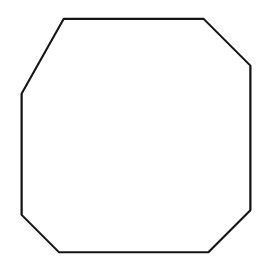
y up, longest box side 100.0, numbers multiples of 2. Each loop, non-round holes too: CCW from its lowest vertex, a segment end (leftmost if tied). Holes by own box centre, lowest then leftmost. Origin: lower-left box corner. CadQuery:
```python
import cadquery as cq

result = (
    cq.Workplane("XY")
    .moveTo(16.0, 0.0)
    .lineTo(80.0, 0.0)
    .lineTo(98.0, 18.0)
    .lineTo(98.0, 80.0)
    .lineTo(78.0, 100.0)
    .lineTo(18.0, 100.0)
    .lineTo(0.0, 68.0)
    .lineTo(0.0, 16.0)
    .close()
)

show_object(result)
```